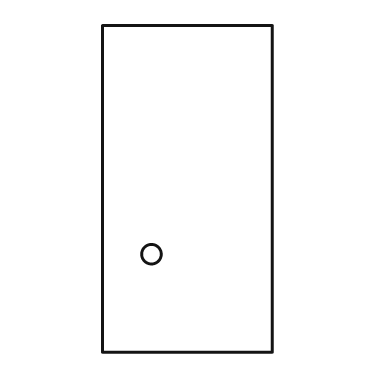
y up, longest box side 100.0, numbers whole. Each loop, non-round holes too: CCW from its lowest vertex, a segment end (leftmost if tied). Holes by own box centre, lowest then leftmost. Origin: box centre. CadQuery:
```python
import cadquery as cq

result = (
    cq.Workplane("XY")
    .moveTo(-26.0, -50.0)
    .lineTo(26.0, -50.0)
    .lineTo(26.0, 50.0)
    .lineTo(-26.0, 50.0)
    .close()
    .moveTo(-11.0, -20.0)
    .circle(3.0)
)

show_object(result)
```